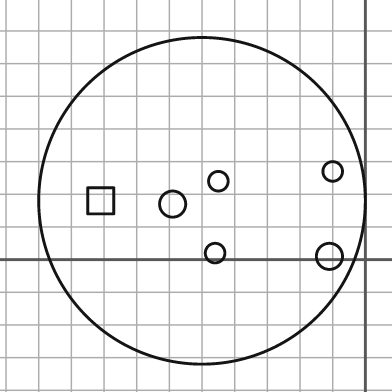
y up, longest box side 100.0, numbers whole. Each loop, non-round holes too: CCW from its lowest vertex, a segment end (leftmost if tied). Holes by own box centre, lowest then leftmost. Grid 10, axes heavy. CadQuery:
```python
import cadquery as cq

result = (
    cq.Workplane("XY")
    .moveTo(-50.0, 18.0)
    .circle(50.0)
    .moveTo(-11.0, 1.0)
    .circle(4.0)
    .moveTo(-46.0, 2.0)
    .circle(3.0)
    .moveTo(-59.0, 17.0)
    .circle(4.0)
    .moveTo(-85.0, 14.0)
    .lineTo(-77.0, 14.0)
    .lineTo(-77.0, 22.0)
    .lineTo(-85.0, 22.0)
    .close()
    .moveTo(-45.0, 24.0)
    .circle(3.0)
    .moveTo(-10.0, 27.0)
    .circle(3.0)
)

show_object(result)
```